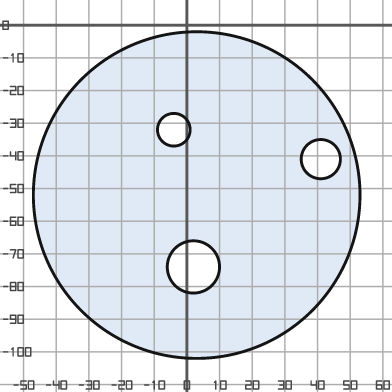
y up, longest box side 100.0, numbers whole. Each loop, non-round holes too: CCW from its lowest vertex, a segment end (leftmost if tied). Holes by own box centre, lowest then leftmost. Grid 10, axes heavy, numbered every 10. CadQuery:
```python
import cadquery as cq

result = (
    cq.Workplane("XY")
    .moveTo(3.0, -52.0)
    .circle(50.0)
    .moveTo(2.0, -74.0)
    .circle(8.0)
    .moveTo(41.0, -41.0)
    .circle(6.0)
    .moveTo(-4.0, -32.0)
    .circle(5.0)
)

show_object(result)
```